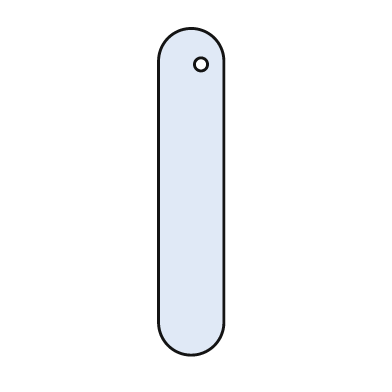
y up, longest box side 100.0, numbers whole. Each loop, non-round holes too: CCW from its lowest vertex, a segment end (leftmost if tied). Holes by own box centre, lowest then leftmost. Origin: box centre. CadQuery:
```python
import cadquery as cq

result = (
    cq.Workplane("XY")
    .moveTo(-10.0, -40.0)
    .threePointArc((0.0, -50.0), (10.0, -40.0))
    .lineTo(10.0, 40.0)
    .threePointArc((0.0, 50.0), (-10.0, 40.0))
    .close()
    .moveTo(3.0, 39.0)
    .circle(2.0)
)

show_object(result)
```